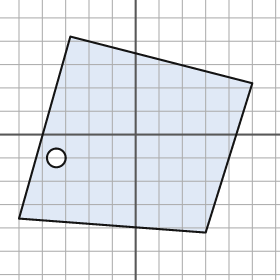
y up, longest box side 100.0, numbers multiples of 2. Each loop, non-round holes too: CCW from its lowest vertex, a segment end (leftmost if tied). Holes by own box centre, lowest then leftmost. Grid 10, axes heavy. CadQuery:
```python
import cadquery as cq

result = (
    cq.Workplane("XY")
    .moveTo(30.0, -42.0)
    .lineTo(50.0, 22.0)
    .lineTo(-28.0, 42.0)
    .lineTo(-50.0, -36.0)
    .close()
    .moveTo(-34.0, -10.0)
    .circle(4.0)
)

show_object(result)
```